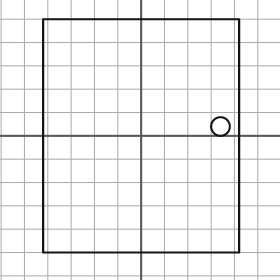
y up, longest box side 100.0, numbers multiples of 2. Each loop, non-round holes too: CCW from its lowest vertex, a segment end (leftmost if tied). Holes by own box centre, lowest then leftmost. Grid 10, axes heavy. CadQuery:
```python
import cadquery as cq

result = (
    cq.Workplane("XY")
    .moveTo(-42.0, -50.0)
    .lineTo(42.0, -50.0)
    .lineTo(42.0, 50.0)
    .lineTo(-42.0, 50.0)
    .close()
    .moveTo(34.0, 4.0)
    .circle(4.0)
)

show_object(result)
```